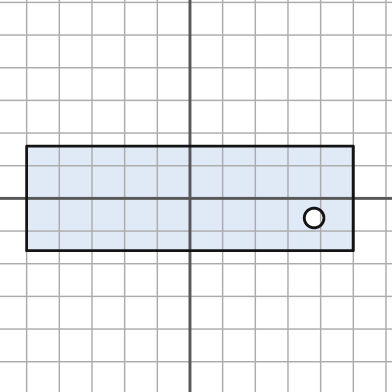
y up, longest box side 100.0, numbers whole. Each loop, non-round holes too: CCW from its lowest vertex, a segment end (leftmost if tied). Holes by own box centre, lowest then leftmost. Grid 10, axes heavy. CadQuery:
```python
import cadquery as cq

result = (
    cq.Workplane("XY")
    .moveTo(-50.0, -16.0)
    .lineTo(50.0, -16.0)
    .lineTo(50.0, 16.0)
    .lineTo(-50.0, 16.0)
    .close()
    .moveTo(38.0, -6.0)
    .circle(3.0)
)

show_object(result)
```